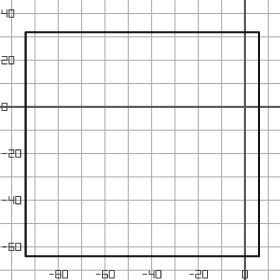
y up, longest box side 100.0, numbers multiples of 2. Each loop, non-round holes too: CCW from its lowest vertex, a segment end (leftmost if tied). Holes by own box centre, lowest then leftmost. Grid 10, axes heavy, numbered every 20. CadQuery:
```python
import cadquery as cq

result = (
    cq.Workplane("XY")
    .moveTo(-94.0, -64.0)
    .lineTo(6.0, -64.0)
    .lineTo(6.0, 32.0)
    .lineTo(-94.0, 32.0)
    .close()
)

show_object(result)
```